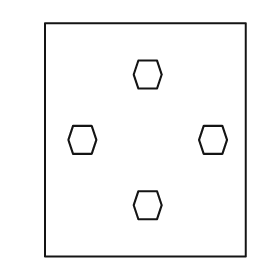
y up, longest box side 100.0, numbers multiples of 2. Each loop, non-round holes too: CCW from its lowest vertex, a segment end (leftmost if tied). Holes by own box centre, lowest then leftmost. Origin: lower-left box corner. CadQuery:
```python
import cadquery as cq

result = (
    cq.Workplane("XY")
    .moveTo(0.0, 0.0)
    .lineTo(86.0, 0.0)
    .lineTo(86.0, 100.0)
    .lineTo(0.0, 100.0)
    .close()
    .moveTo(40.0, 16.0)
    .lineTo(48.0, 16.0)
    .lineTo(50.0, 22.0)
    .lineTo(48.0, 28.0)
    .lineTo(40.0, 28.0)
    .lineTo(38.0, 22.0)
    .close()
    .moveTo(12.0, 44.0)
    .lineTo(20.0, 44.0)
    .lineTo(22.0, 50.0)
    .lineTo(20.0, 56.0)
    .lineTo(12.0, 56.0)
    .lineTo(10.0, 50.0)
    .close()
    .moveTo(68.0, 44.0)
    .lineTo(76.0, 44.0)
    .lineTo(78.0, 50.0)
    .lineTo(76.0, 56.0)
    .lineTo(68.0, 56.0)
    .lineTo(66.0, 50.0)
    .close()
    .moveTo(40.0, 72.0)
    .lineTo(48.0, 72.0)
    .lineTo(50.0, 78.0)
    .lineTo(48.0, 84.0)
    .lineTo(40.0, 84.0)
    .lineTo(38.0, 78.0)
    .close()
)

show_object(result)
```